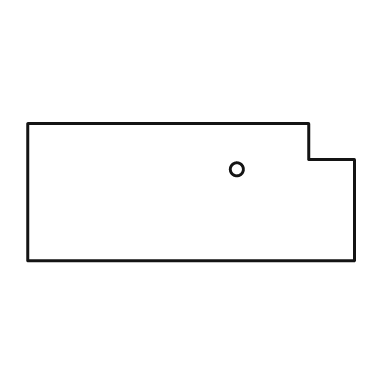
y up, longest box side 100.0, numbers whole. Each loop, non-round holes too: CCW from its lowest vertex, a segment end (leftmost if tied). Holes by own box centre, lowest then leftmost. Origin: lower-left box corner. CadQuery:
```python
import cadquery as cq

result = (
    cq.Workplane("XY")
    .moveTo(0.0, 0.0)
    .lineTo(100.0, 0.0)
    .lineTo(100.0, 31.0)
    .lineTo(86.0, 31.0)
    .lineTo(86.0, 42.0)
    .lineTo(0.0, 42.0)
    .close()
    .moveTo(64.0, 28.0)
    .circle(2.0)
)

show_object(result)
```